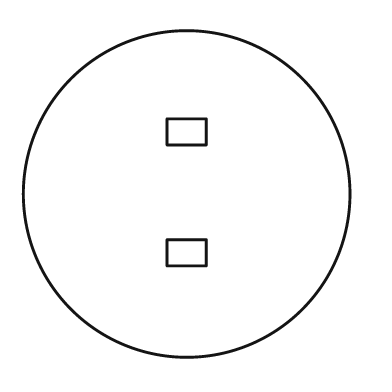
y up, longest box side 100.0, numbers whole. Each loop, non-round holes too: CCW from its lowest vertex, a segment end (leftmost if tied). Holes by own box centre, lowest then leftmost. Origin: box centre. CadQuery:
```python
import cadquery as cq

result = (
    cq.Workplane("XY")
    .moveTo(0.0, 0.0)
    .circle(50.0)
    .moveTo(-6.0, -22.0)
    .lineTo(6.0, -22.0)
    .lineTo(6.0, -14.0)
    .lineTo(-6.0, -14.0)
    .close()
    .moveTo(-6.0, 15.0)
    .lineTo(6.0, 15.0)
    .lineTo(6.0, 23.0)
    .lineTo(-6.0, 23.0)
    .close()
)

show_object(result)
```